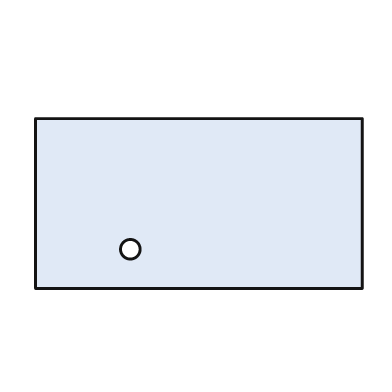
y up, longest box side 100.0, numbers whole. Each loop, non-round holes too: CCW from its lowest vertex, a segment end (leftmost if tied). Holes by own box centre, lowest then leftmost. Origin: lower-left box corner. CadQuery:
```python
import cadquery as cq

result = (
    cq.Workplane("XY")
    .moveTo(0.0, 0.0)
    .lineTo(100.0, 0.0)
    .lineTo(100.0, 52.0)
    .lineTo(0.0, 52.0)
    .close()
    .moveTo(29.0, 12.0)
    .circle(3.0)
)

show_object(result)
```